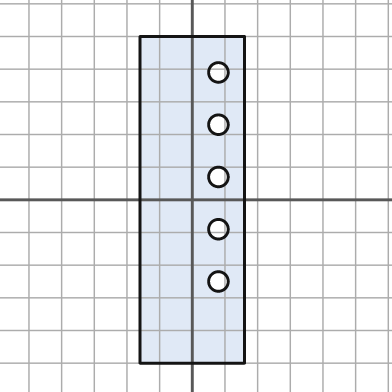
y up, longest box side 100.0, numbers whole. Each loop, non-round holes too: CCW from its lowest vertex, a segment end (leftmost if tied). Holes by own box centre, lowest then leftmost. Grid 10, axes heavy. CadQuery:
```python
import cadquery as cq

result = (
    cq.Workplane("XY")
    .moveTo(-16.0, -50.0)
    .lineTo(16.0, -50.0)
    .lineTo(16.0, 50.0)
    .lineTo(-16.0, 50.0)
    .close()
    .moveTo(8.0, -25.0)
    .circle(3.0)
    .moveTo(8.0, -9.0)
    .circle(3.0)
    .moveTo(8.0, 7.0)
    .circle(3.0)
    .moveTo(8.0, 23.0)
    .circle(3.0)
    .moveTo(8.0, 39.0)
    .circle(3.0)
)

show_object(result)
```